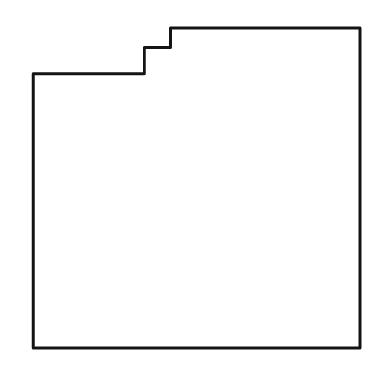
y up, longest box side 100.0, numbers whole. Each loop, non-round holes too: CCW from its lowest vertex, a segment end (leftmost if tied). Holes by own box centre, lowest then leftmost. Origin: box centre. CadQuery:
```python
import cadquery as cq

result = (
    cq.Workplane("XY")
    .moveTo(-50.0, -49.0)
    .lineTo(50.0, -49.0)
    .lineTo(50.0, 49.0)
    .lineTo(-8.0, 49.0)
    .lineTo(-8.0, 43.0)
    .lineTo(-16.0, 43.0)
    .lineTo(-16.0, 35.0)
    .lineTo(-50.0, 35.0)
    .close()
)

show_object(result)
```